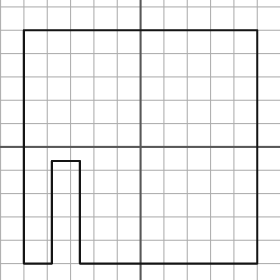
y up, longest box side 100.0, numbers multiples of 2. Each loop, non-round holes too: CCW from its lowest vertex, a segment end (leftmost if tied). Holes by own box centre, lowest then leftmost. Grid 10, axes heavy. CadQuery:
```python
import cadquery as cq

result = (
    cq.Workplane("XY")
    .moveTo(-50.0, -50.0)
    .lineTo(-38.0, -50.0)
    .lineTo(-38.0, -6.0)
    .lineTo(-26.0, -6.0)
    .lineTo(-26.0, -50.0)
    .lineTo(50.0, -50.0)
    .lineTo(50.0, 50.0)
    .lineTo(-50.0, 50.0)
    .close()
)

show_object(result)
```